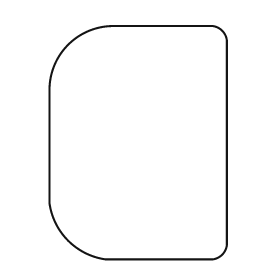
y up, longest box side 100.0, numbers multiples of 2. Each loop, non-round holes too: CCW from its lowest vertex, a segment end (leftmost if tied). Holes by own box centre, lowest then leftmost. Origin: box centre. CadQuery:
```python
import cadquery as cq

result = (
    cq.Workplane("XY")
    .moveTo(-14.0, -50.0)
    .lineTo(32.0, -50.0)
    .threePointArc((36.0, -48.0), (38.0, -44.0))
    .lineTo(38.0, 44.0)
    .threePointArc((36.0, 48.0), (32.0, 50.0))
    .lineTo(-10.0, 50.0)
    .threePointArc((-30.0, 42.0), (-38.0, 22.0))
    .lineTo(-38.0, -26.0)
    .threePointArc((-30.0, -42.0), (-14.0, -50.0))
    .close()
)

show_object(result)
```